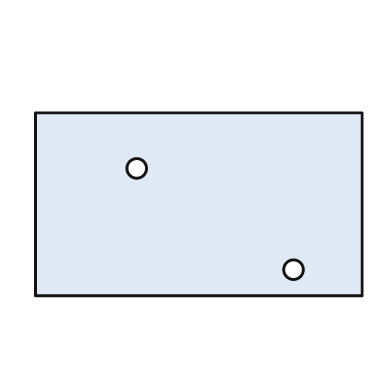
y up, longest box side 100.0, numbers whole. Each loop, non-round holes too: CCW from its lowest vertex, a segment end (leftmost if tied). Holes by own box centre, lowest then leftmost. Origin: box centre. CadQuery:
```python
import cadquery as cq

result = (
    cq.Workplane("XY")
    .moveTo(-50.0, -28.0)
    .lineTo(50.0, -28.0)
    .lineTo(50.0, 28.0)
    .lineTo(-50.0, 28.0)
    .close()
    .moveTo(29.0, -20.0)
    .circle(3.0)
    .moveTo(-19.0, 11.0)
    .circle(3.0)
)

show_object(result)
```